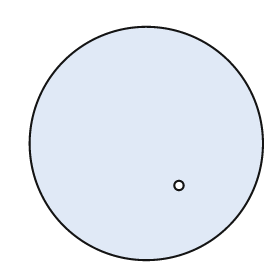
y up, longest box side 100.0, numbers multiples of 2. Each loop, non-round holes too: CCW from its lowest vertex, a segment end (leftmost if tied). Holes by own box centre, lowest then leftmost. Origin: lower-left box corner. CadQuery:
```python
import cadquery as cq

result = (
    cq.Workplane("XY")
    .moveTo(50.0, 50.0)
    .circle(50.0)
    .moveTo(64.0, 32.0)
    .circle(2.0)
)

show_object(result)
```